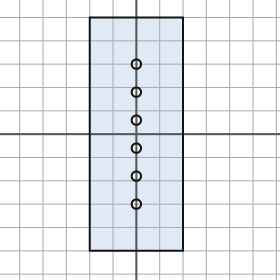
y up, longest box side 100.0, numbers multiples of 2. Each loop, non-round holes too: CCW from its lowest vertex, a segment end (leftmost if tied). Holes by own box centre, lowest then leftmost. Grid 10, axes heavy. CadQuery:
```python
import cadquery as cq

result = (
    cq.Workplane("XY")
    .moveTo(-20.0, -50.0)
    .lineTo(20.0, -50.0)
    .lineTo(20.0, 50.0)
    .lineTo(-20.0, 50.0)
    .close()
    .moveTo(0.0, -30.0)
    .circle(2.0)
    .moveTo(0.0, -18.0)
    .circle(2.0)
    .moveTo(0.0, -6.0)
    .circle(2.0)
    .moveTo(0.0, 6.0)
    .circle(2.0)
    .moveTo(0.0, 18.0)
    .circle(2.0)
    .moveTo(0.0, 30.0)
    .circle(2.0)
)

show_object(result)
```